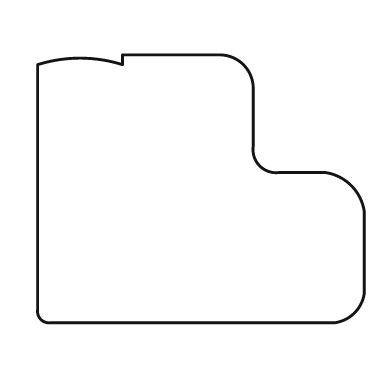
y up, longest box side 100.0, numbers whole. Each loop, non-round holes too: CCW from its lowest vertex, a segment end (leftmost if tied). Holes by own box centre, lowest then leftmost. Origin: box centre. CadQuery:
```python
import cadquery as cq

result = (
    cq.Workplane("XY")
    .moveTo(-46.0, -41.0)
    .lineTo(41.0, -41.0)
    .threePointArc((47.0, -38.0), (50.0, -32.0))
    .lineTo(50.0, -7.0)
    .threePointArc((46.0, 1.0), (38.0, 5.0))
    .lineTo(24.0, 5.0)
    .threePointArc((18.0, 7.0), (16.0, 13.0))
    .lineTo(16.0, 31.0)
    .threePointArc((13.0, 38.0), (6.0, 41.0))
    .lineTo(-24.0, 41.0)
    .lineTo(-24.0, 38.0)
    .threePointArc((-37.0, 40.0), (-50.0, 38.0))
    .lineTo(-50.0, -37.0)
    .threePointArc((-49.0, -40.0), (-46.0, -41.0))
    .close()
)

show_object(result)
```